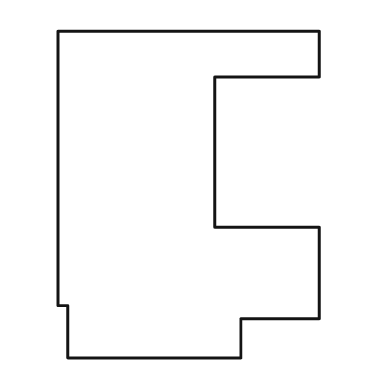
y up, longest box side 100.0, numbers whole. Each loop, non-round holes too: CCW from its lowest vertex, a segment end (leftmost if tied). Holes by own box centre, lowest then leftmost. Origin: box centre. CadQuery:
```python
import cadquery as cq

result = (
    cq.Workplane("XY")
    .moveTo(-37.0, -50.0)
    .lineTo(16.0, -50.0)
    .lineTo(16.0, -38.0)
    .lineTo(40.0, -38.0)
    .lineTo(40.0, -10.0)
    .lineTo(8.0, -10.0)
    .lineTo(8.0, 36.0)
    .lineTo(40.0, 36.0)
    .lineTo(40.0, 50.0)
    .lineTo(-40.0, 50.0)
    .lineTo(-40.0, -34.0)
    .lineTo(-37.0, -34.0)
    .close()
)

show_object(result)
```